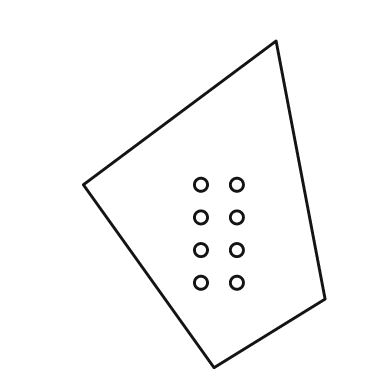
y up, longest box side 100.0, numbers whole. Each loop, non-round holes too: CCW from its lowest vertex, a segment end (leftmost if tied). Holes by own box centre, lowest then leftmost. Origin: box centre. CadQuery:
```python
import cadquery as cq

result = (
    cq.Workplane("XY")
    .moveTo(3.0, -50.0)
    .lineTo(37.0, -29.0)
    .lineTo(22.0, 50.0)
    .lineTo(-37.0, 6.0)
    .close()
    .moveTo(-1.0, -24.0)
    .circle(2.0)
    .moveTo(10.0, -24.0)
    .circle(2.0)
    .moveTo(-1.0, -14.0)
    .circle(2.0)
    .moveTo(10.0, -14.0)
    .circle(2.0)
    .moveTo(-1.0, -4.0)
    .circle(2.0)
    .moveTo(10.0, -4.0)
    .circle(2.0)
    .moveTo(-1.0, 6.0)
    .circle(2.0)
    .moveTo(10.0, 6.0)
    .circle(2.0)
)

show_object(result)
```